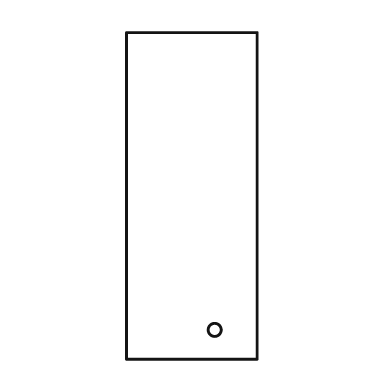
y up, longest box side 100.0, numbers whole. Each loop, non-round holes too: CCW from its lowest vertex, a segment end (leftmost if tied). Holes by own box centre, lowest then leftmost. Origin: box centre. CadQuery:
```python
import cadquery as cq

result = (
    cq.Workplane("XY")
    .moveTo(-20.0, -50.0)
    .lineTo(20.0, -50.0)
    .lineTo(20.0, 50.0)
    .lineTo(-20.0, 50.0)
    .close()
    .moveTo(7.0, -41.0)
    .circle(2.0)
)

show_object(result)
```